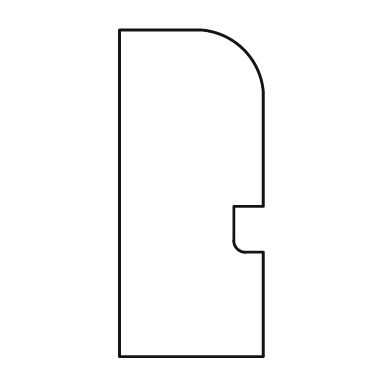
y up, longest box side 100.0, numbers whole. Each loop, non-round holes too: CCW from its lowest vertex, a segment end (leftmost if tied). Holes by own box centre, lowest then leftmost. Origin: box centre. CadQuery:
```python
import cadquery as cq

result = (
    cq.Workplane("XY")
    .moveTo(-22.0, -50.0)
    .lineTo(22.0, -50.0)
    .lineTo(22.0, -18.0)
    .lineTo(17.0, -18.0)
    .threePointArc((14.0, -17.0), (13.0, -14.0))
    .lineTo(13.0, -4.0)
    .lineTo(22.0, -4.0)
    .lineTo(22.0, 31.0)
    .threePointArc((16.0, 44.0), (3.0, 50.0))
    .lineTo(-22.0, 50.0)
    .close()
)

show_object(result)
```